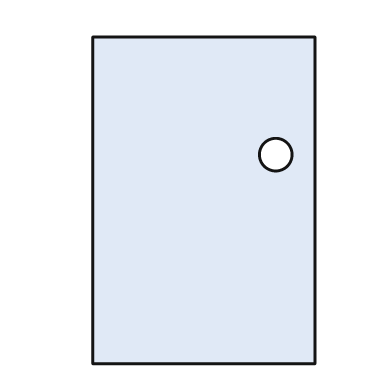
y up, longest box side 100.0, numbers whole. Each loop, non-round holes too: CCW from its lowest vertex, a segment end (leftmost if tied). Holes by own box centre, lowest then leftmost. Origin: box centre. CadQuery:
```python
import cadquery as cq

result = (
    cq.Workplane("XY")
    .moveTo(-34.0, -50.0)
    .lineTo(34.0, -50.0)
    .lineTo(34.0, 50.0)
    .lineTo(-34.0, 50.0)
    .close()
    .moveTo(22.0, 14.0)
    .circle(5.0)
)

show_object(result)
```